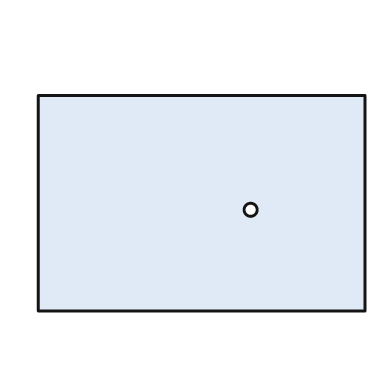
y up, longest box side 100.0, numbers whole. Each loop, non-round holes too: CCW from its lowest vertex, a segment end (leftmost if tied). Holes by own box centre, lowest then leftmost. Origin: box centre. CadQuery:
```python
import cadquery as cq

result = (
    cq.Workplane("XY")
    .moveTo(-50.0, -33.0)
    .lineTo(50.0, -33.0)
    .lineTo(50.0, 33.0)
    .lineTo(-50.0, 33.0)
    .close()
    .moveTo(15.0, -2.0)
    .circle(2.0)
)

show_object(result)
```